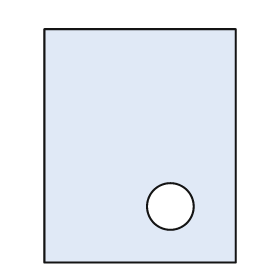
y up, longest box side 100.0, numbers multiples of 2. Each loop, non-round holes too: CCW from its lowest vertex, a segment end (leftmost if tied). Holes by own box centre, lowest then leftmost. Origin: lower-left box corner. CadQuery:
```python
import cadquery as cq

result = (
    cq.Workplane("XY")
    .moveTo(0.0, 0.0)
    .lineTo(82.0, 0.0)
    .lineTo(82.0, 100.0)
    .lineTo(0.0, 100.0)
    .close()
    .moveTo(54.0, 24.0)
    .circle(10.0)
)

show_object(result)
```